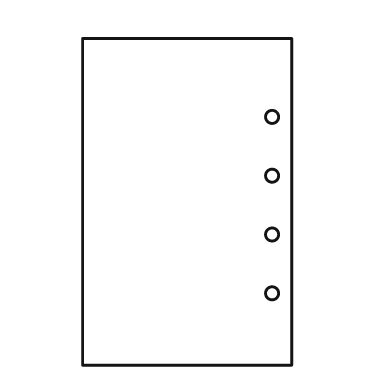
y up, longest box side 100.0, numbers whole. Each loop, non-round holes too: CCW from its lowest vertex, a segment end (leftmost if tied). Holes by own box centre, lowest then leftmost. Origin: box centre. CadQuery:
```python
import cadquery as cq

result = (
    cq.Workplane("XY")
    .moveTo(-32.0, -50.0)
    .lineTo(32.0, -50.0)
    .lineTo(32.0, 50.0)
    .lineTo(-32.0, 50.0)
    .close()
    .moveTo(26.0, -28.0)
    .circle(2.0)
    .moveTo(26.0, -10.0)
    .circle(2.0)
    .moveTo(26.0, 8.0)
    .circle(2.0)
    .moveTo(26.0, 26.0)
    .circle(2.0)
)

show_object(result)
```